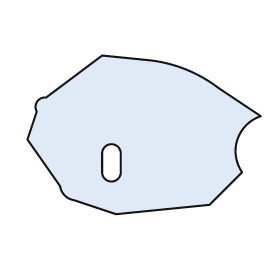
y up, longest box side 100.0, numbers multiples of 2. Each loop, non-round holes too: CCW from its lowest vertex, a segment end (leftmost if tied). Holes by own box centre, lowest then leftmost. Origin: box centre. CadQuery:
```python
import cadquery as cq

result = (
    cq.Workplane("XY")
    .moveTo(-12.0, -34.0)
    .lineTo(28.0, -30.0)
    .lineTo(42.0, -16.0)
    .threePointArc((40.0, -2.0), (50.0, 8.0))
    .lineTo(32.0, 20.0)
    .threePointArc((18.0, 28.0), (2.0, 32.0))
    .lineTo(-18.0, 34.0)
    .lineTo(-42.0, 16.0)
    .threePointArc((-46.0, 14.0), (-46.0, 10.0))
    .lineTo(-50.0, -2.0)
    .lineTo(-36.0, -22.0)
    .threePointArc((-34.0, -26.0), (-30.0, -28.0))
    .close()
    .moveTo(-18.0, -16.0)
    .threePointArc((-14.0, -20.0), (-10.0, -16.0))
    .lineTo(-10.0, -8.0)
    .threePointArc((-14.0, -4.0), (-18.0, -8.0))
    .close()
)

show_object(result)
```